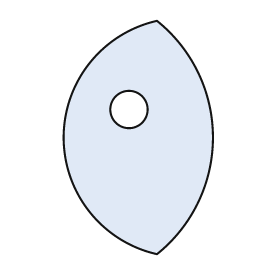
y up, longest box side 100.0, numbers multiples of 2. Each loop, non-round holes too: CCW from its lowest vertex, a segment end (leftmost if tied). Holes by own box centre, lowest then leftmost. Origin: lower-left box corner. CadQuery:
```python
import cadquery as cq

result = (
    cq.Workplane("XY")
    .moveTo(40.0, 0.0)
    .threePointArc((64.0, 50.0), (40.0, 100.0))
    .threePointArc((0.0, 50.0), (40.0, 0.0))
    .close()
    .moveTo(28.0, 62.0)
    .circle(8.0)
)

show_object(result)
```